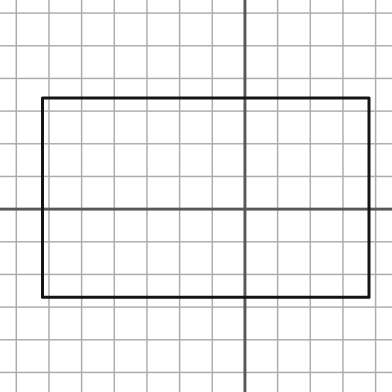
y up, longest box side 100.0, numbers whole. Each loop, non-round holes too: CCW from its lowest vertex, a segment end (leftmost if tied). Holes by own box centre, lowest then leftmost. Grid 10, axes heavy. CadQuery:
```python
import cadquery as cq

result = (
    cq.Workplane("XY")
    .moveTo(-62.0, -27.0)
    .lineTo(38.0, -27.0)
    .lineTo(38.0, 34.0)
    .lineTo(-62.0, 34.0)
    .close()
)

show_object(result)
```